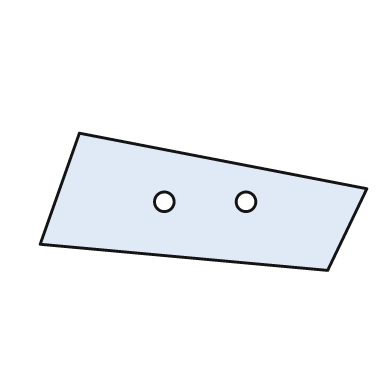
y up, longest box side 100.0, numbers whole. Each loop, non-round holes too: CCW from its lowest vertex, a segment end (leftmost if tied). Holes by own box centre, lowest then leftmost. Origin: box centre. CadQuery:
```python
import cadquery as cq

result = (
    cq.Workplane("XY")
    .moveTo(38.0, -21.0)
    .lineTo(50.0, 4.0)
    .lineTo(-38.0, 21.0)
    .lineTo(-50.0, -13.0)
    .close()
    .moveTo(-12.0, 0.0)
    .circle(3.0)
    .moveTo(13.0, 0.0)
    .circle(3.0)
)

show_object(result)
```